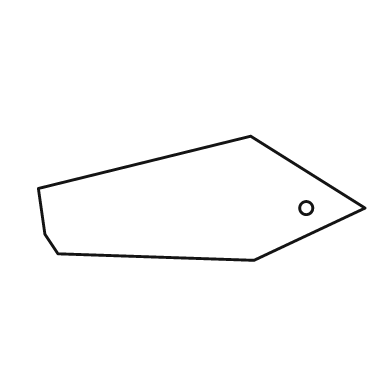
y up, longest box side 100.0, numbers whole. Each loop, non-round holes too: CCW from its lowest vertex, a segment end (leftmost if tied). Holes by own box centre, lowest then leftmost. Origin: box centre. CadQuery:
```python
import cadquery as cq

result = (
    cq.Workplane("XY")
    .moveTo(16.0, -19.0)
    .lineTo(50.0, -3.0)
    .lineTo(15.0, 19.0)
    .lineTo(-50.0, 3.0)
    .lineTo(-48.0, -11.0)
    .lineTo(-44.0, -17.0)
    .close()
    .moveTo(32.0, -3.0)
    .circle(2.0)
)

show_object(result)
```